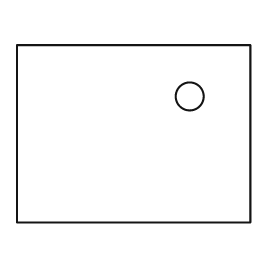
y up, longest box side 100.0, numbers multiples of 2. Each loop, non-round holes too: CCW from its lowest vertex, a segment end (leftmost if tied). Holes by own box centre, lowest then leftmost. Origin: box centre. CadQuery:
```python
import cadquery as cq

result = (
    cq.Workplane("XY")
    .moveTo(-50.0, -38.0)
    .lineTo(50.0, -38.0)
    .lineTo(50.0, 38.0)
    .lineTo(-50.0, 38.0)
    .close()
    .moveTo(24.0, 16.0)
    .circle(6.0)
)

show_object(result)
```